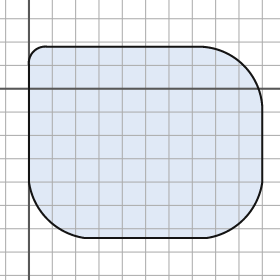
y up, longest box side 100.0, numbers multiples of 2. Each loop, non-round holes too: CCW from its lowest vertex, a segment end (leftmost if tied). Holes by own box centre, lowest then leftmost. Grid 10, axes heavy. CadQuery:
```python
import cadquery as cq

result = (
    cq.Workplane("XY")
    .moveTo(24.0, -64.0)
    .lineTo(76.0, -64.0)
    .threePointArc((92.0, -56.0), (100.0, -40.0))
    .lineTo(100.0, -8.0)
    .threePointArc((92.0, 10.0), (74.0, 18.0))
    .lineTo(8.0, 18.0)
    .threePointArc((2.0, 16.0), (0.0, 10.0))
    .lineTo(0.0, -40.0)
    .threePointArc((8.0, -56.0), (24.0, -64.0))
    .close()
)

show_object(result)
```